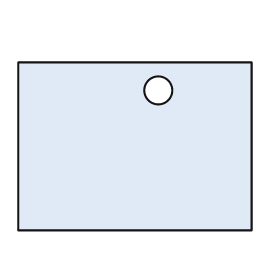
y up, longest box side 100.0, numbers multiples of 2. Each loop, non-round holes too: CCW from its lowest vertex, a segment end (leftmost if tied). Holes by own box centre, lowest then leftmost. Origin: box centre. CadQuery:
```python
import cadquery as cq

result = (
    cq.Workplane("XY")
    .moveTo(-50.0, -36.0)
    .lineTo(50.0, -36.0)
    .lineTo(50.0, 36.0)
    .lineTo(-50.0, 36.0)
    .close()
    .moveTo(10.0, 24.0)
    .circle(6.0)
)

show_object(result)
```